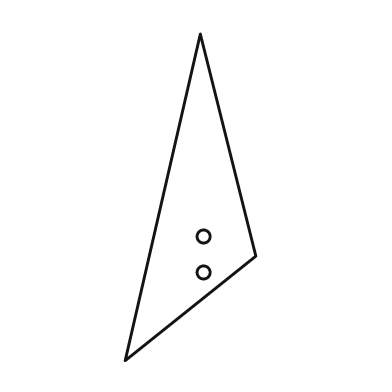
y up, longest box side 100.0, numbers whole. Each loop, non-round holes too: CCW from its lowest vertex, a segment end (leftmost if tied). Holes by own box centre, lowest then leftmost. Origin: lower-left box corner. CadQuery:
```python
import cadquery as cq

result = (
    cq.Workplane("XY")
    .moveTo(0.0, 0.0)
    .lineTo(40.0, 32.0)
    .lineTo(23.0, 100.0)
    .close()
    .moveTo(24.0, 27.0)
    .circle(2.0)
    .moveTo(24.0, 38.0)
    .circle(2.0)
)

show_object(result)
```